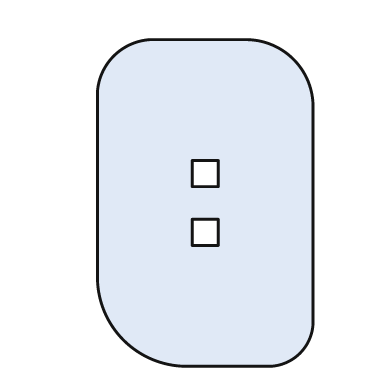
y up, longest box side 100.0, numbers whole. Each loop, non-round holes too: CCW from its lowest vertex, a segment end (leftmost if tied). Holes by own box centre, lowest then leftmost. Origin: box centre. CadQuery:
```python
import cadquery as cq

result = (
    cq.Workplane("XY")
    .moveTo(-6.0, -50.0)
    .lineTo(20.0, -50.0)
    .threePointArc((29.0, -46.0), (33.0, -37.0))
    .lineTo(33.0, 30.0)
    .threePointArc((27.0, 44.0), (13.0, 50.0))
    .lineTo(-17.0, 50.0)
    .threePointArc((-28.0, 45.0), (-33.0, 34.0))
    .lineTo(-33.0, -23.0)
    .threePointArc((-25.0, -42.0), (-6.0, -50.0))
    .close()
    .moveTo(-4.0, -13.0)
    .lineTo(4.0, -13.0)
    .lineTo(4.0, -5.0)
    .lineTo(-4.0, -5.0)
    .close()
    .moveTo(-4.0, 5.0)
    .lineTo(4.0, 5.0)
    .lineTo(4.0, 13.0)
    .lineTo(-4.0, 13.0)
    .close()
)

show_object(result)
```